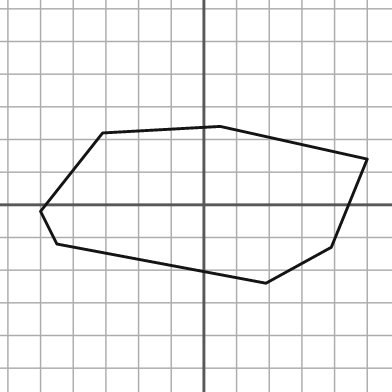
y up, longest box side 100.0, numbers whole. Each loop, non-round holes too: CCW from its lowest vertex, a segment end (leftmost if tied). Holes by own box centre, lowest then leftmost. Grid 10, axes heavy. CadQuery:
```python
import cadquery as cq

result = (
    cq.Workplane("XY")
    .moveTo(19.0, -24.0)
    .lineTo(39.0, -13.0)
    .lineTo(50.0, 14.0)
    .lineTo(5.0, 24.0)
    .lineTo(-31.0, 22.0)
    .lineTo(-50.0, -2.0)
    .lineTo(-45.0, -12.0)
    .close()
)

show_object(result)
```